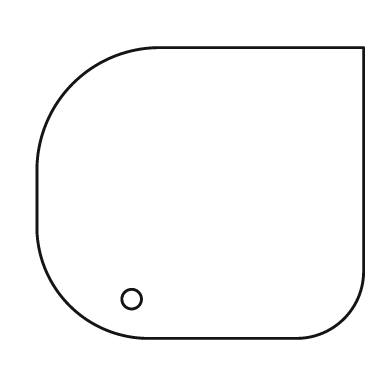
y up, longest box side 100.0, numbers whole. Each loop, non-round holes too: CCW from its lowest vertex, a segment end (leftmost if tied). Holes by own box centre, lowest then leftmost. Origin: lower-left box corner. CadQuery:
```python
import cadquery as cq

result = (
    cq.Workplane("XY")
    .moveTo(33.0, 0.0)
    .lineTo(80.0, 0.0)
    .threePointArc((94.0, 6.0), (100.0, 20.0))
    .lineTo(100.0, 89.0)
    .lineTo(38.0, 89.0)
    .threePointArc((11.0, 78.0), (0.0, 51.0))
    .lineTo(0.0, 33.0)
    .threePointArc((10.0, 10.0), (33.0, 0.0))
    .close()
    .moveTo(29.0, 12.0)
    .circle(3.0)
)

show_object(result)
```